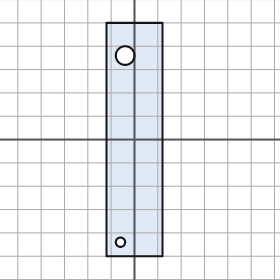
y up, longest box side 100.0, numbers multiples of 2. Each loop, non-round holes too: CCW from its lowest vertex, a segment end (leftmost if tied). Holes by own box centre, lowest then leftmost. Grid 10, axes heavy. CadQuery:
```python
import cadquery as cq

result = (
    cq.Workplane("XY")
    .moveTo(-12.0, -50.0)
    .lineTo(12.0, -50.0)
    .lineTo(12.0, 50.0)
    .lineTo(-12.0, 50.0)
    .close()
    .moveTo(-6.0, -44.0)
    .circle(2.0)
    .moveTo(-4.0, 36.0)
    .circle(4.0)
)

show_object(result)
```